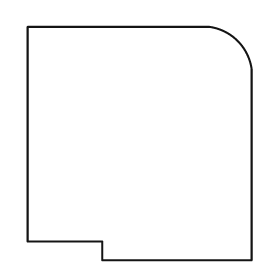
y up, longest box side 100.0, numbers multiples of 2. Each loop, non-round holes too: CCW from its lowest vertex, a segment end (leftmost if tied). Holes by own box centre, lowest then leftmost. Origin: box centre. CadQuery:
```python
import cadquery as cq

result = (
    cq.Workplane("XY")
    .moveTo(-16.0, -50.0)
    .lineTo(48.0, -50.0)
    .lineTo(48.0, 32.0)
    .threePointArc((42.0, 44.0), (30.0, 50.0))
    .lineTo(-48.0, 50.0)
    .lineTo(-48.0, -42.0)
    .lineTo(-16.0, -42.0)
    .close()
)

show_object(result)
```